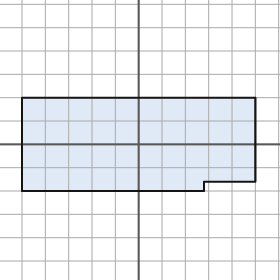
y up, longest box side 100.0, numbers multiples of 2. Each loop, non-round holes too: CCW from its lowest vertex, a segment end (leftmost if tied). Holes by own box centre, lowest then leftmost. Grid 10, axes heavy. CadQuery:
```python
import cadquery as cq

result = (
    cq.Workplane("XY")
    .moveTo(-50.0, -20.0)
    .lineTo(28.0, -20.0)
    .lineTo(28.0, -16.0)
    .lineTo(50.0, -16.0)
    .lineTo(50.0, 20.0)
    .lineTo(-50.0, 20.0)
    .close()
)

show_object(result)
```